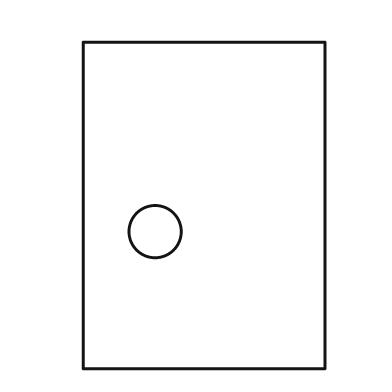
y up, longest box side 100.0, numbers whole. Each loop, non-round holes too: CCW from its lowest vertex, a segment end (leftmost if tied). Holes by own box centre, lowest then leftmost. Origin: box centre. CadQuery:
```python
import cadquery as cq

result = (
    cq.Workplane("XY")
    .moveTo(-37.0, -50.0)
    .lineTo(37.0, -50.0)
    .lineTo(37.0, 50.0)
    .lineTo(-37.0, 50.0)
    .close()
    .moveTo(-15.0, -8.0)
    .circle(8.0)
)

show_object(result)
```